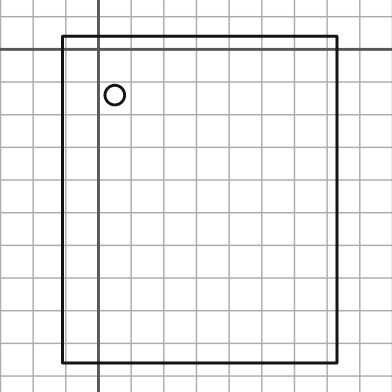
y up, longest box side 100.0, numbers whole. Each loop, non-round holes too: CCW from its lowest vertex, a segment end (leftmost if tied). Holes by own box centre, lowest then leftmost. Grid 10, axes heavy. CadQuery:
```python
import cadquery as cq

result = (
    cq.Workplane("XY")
    .moveTo(-11.0, -96.0)
    .lineTo(73.0, -96.0)
    .lineTo(73.0, 4.0)
    .lineTo(-11.0, 4.0)
    .close()
    .moveTo(5.0, -14.0)
    .circle(3.0)
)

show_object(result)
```